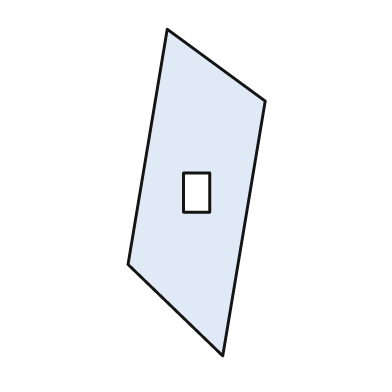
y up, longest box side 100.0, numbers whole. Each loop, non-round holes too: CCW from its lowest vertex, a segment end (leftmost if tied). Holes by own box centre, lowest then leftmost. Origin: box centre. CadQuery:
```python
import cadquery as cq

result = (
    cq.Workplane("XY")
    .moveTo(8.0, -50.0)
    .lineTo(21.0, 28.0)
    .lineTo(-9.0, 50.0)
    .lineTo(-21.0, -22.0)
    .close()
    .moveTo(-4.0, -6.0)
    .lineTo(4.0, -6.0)
    .lineTo(4.0, 6.0)
    .lineTo(-4.0, 6.0)
    .close()
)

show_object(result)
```